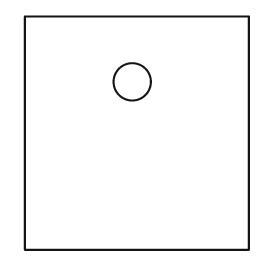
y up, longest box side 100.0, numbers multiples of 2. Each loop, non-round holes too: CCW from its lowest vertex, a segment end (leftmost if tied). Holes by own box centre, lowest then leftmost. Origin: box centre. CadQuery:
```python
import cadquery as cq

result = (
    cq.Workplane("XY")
    .moveTo(-48.0, -50.0)
    .lineTo(48.0, -50.0)
    .lineTo(48.0, 50.0)
    .lineTo(-48.0, 50.0)
    .close()
    .moveTo(-2.0, 22.0)
    .circle(8.0)
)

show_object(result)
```